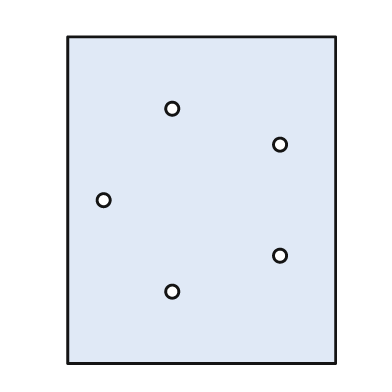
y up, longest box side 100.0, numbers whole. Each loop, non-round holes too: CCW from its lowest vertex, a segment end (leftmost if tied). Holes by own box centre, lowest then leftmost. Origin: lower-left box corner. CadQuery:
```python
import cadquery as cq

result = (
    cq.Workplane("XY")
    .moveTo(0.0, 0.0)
    .lineTo(82.0, 0.0)
    .lineTo(82.0, 100.0)
    .lineTo(0.0, 100.0)
    .close()
    .moveTo(32.0, 22.0)
    .circle(2.0)
    .moveTo(65.0, 33.0)
    .circle(2.0)
    .moveTo(11.0, 50.0)
    .circle(2.0)
    .moveTo(65.0, 67.0)
    .circle(2.0)
    .moveTo(32.0, 78.0)
    .circle(2.0)
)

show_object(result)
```